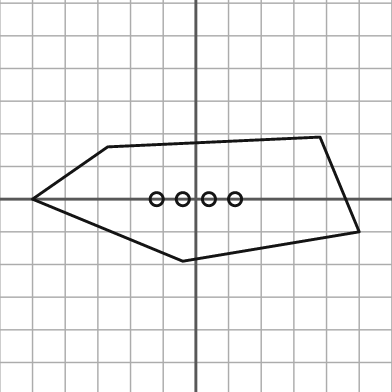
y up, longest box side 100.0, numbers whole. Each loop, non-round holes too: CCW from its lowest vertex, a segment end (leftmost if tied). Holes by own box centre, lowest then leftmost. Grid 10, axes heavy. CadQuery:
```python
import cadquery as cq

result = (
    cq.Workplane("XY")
    .moveTo(-4.0, -19.0)
    .lineTo(50.0, -10.0)
    .lineTo(38.0, 19.0)
    .lineTo(-27.0, 16.0)
    .lineTo(-50.0, 0.0)
    .close()
    .moveTo(-12.0, 0.0)
    .circle(2.0)
    .moveTo(-4.0, 0.0)
    .circle(2.0)
    .moveTo(4.0, 0.0)
    .circle(2.0)
    .moveTo(12.0, 0.0)
    .circle(2.0)
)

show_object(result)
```